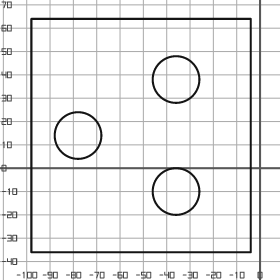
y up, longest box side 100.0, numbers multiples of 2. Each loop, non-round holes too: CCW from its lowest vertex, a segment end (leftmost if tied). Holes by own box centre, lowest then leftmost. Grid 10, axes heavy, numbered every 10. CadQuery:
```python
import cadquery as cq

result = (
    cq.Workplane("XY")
    .moveTo(-98.0, -36.0)
    .lineTo(-4.0, -36.0)
    .lineTo(-4.0, 64.0)
    .lineTo(-98.0, 64.0)
    .close()
    .moveTo(-36.0, -10.0)
    .circle(10.0)
    .moveTo(-78.0, 14.0)
    .circle(10.0)
    .moveTo(-36.0, 38.0)
    .circle(10.0)
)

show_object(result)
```